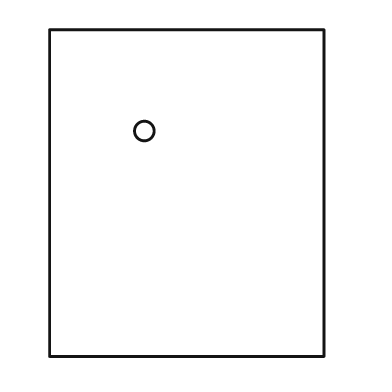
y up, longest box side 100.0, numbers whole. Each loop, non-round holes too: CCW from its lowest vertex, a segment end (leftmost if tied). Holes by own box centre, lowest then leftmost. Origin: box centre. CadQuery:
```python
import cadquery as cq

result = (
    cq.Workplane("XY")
    .moveTo(-42.0, -50.0)
    .lineTo(42.0, -50.0)
    .lineTo(42.0, 50.0)
    .lineTo(-42.0, 50.0)
    .close()
    .moveTo(-13.0, 19.0)
    .circle(3.0)
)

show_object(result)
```